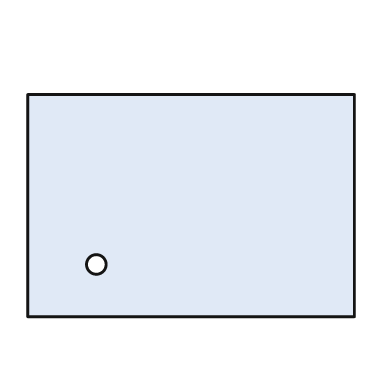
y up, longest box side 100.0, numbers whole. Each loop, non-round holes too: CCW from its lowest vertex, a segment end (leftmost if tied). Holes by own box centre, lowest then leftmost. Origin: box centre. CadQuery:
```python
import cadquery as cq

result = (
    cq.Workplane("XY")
    .moveTo(-50.0, -34.0)
    .lineTo(50.0, -34.0)
    .lineTo(50.0, 34.0)
    .lineTo(-50.0, 34.0)
    .close()
    .moveTo(-29.0, -18.0)
    .circle(3.0)
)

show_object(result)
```